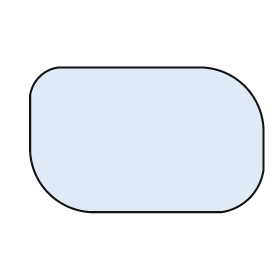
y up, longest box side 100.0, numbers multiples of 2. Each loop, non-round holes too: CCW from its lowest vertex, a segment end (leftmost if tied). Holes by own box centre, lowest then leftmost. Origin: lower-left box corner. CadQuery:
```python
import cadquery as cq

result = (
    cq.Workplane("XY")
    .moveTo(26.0, 0.0)
    .lineTo(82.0, 0.0)
    .threePointArc((94.0, 6.0), (100.0, 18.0))
    .lineTo(100.0, 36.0)
    .threePointArc((92.0, 54.0), (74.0, 62.0))
    .lineTo(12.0, 62.0)
    .threePointArc((4.0, 58.0), (0.0, 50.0))
    .lineTo(0.0, 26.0)
    .threePointArc((8.0, 8.0), (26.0, 0.0))
    .close()
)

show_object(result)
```